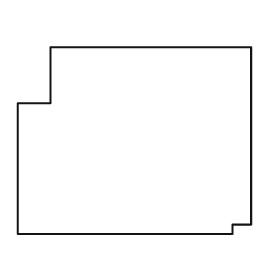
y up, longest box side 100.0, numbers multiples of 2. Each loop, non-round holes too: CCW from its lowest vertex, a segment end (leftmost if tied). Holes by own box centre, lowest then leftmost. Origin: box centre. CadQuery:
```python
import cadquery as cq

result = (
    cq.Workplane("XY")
    .moveTo(-50.0, -40.0)
    .lineTo(42.0, -40.0)
    .lineTo(42.0, -36.0)
    .lineTo(50.0, -36.0)
    .lineTo(50.0, 40.0)
    .lineTo(-36.0, 40.0)
    .lineTo(-36.0, 16.0)
    .lineTo(-50.0, 16.0)
    .close()
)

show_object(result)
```